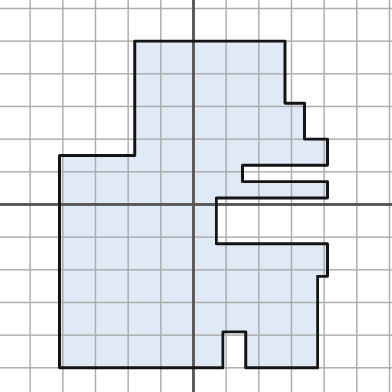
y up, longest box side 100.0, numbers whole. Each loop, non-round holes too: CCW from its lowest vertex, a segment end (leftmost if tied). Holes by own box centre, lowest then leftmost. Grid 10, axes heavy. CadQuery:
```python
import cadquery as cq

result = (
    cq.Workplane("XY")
    .moveTo(-41.0, -50.0)
    .lineTo(9.0, -50.0)
    .lineTo(9.0, -39.0)
    .lineTo(16.0, -39.0)
    .lineTo(16.0, -50.0)
    .lineTo(38.0, -50.0)
    .lineTo(38.0, -22.0)
    .lineTo(41.0, -22.0)
    .lineTo(41.0, -12.0)
    .lineTo(7.0, -12.0)
    .lineTo(7.0, 2.0)
    .lineTo(41.0, 2.0)
    .lineTo(41.0, 7.0)
    .lineTo(15.0, 7.0)
    .lineTo(15.0, 12.0)
    .lineTo(41.0, 12.0)
    .lineTo(41.0, 20.0)
    .lineTo(34.0, 20.0)
    .lineTo(34.0, 31.0)
    .lineTo(28.0, 31.0)
    .lineTo(28.0, 50.0)
    .lineTo(-18.0, 50.0)
    .lineTo(-18.0, 15.0)
    .lineTo(-41.0, 15.0)
    .close()
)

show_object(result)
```